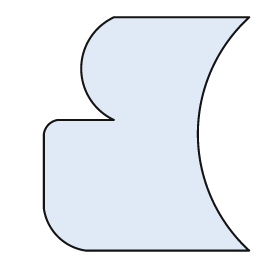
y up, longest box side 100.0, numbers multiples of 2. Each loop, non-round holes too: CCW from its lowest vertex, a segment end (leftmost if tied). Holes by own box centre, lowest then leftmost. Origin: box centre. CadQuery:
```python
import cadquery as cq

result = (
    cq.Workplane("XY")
    .moveTo(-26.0, -50.0)
    .lineTo(44.0, -50.0)
    .threePointArc((22.0, 0.0), (44.0, 50.0))
    .lineTo(-14.0, 50.0)
    .threePointArc((-28.0, 28.0), (-14.0, 6.0))
    .lineTo(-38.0, 6.0)
    .threePointArc((-42.0, 4.0), (-44.0, 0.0))
    .lineTo(-44.0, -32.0)
    .threePointArc((-38.0, -44.0), (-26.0, -50.0))
    .close()
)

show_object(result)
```